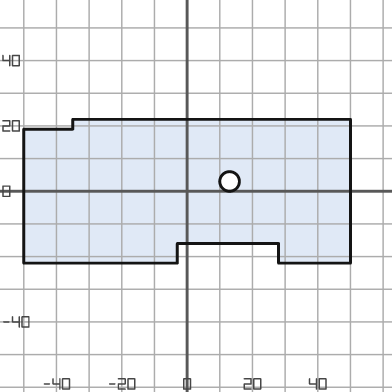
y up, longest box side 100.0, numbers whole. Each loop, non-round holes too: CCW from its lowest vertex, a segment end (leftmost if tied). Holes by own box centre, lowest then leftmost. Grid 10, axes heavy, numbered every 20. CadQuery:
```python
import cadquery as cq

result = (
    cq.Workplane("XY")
    .moveTo(-50.0, -22.0)
    .lineTo(-3.0, -22.0)
    .lineTo(-3.0, -16.0)
    .lineTo(28.0, -16.0)
    .lineTo(28.0, -22.0)
    .lineTo(50.0, -22.0)
    .lineTo(50.0, 22.0)
    .lineTo(-35.0, 22.0)
    .lineTo(-35.0, 19.0)
    .lineTo(-50.0, 19.0)
    .close()
    .moveTo(13.0, 3.0)
    .circle(3.0)
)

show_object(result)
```